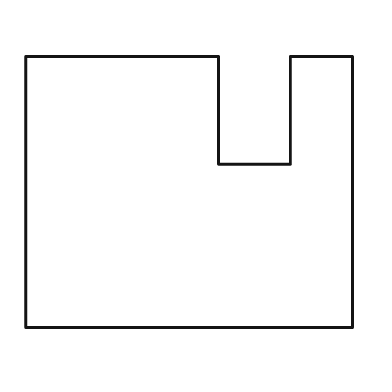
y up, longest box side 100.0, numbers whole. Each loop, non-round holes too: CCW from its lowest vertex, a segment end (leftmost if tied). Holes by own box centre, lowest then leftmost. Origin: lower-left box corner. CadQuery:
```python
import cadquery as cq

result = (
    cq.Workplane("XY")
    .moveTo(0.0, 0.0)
    .lineTo(100.0, 0.0)
    .lineTo(100.0, 83.0)
    .lineTo(81.0, 83.0)
    .lineTo(81.0, 50.0)
    .lineTo(59.0, 50.0)
    .lineTo(59.0, 83.0)
    .lineTo(0.0, 83.0)
    .close()
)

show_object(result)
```